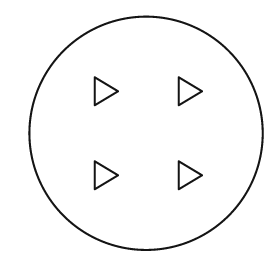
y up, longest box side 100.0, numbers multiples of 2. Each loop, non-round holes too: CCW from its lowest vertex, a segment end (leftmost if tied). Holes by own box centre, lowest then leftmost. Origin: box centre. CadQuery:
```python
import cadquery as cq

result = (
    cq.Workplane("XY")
    .moveTo(0.0, 0.0)
    .circle(50.0)
    .moveTo(-22.0, -24.0)
    .lineTo(-12.0, -18.0)
    .lineTo(-22.0, -12.0)
    .close()
    .moveTo(14.0, -24.0)
    .lineTo(24.0, -18.0)
    .lineTo(14.0, -12.0)
    .close()
    .moveTo(-22.0, 12.0)
    .lineTo(-12.0, 18.0)
    .lineTo(-22.0, 24.0)
    .close()
    .moveTo(14.0, 12.0)
    .lineTo(24.0, 18.0)
    .lineTo(14.0, 24.0)
    .close()
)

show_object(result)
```